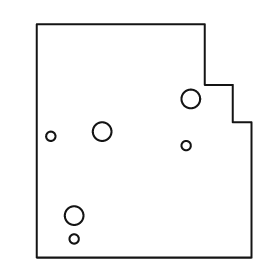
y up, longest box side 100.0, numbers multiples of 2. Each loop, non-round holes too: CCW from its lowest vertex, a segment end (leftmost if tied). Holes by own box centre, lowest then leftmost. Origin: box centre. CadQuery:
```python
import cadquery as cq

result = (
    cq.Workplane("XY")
    .moveTo(-46.0, -50.0)
    .lineTo(46.0, -50.0)
    .lineTo(46.0, 8.0)
    .lineTo(38.0, 8.0)
    .lineTo(38.0, 24.0)
    .lineTo(26.0, 24.0)
    .lineTo(26.0, 50.0)
    .lineTo(-46.0, 50.0)
    .close()
    .moveTo(-30.0, -42.0)
    .circle(2.0)
    .moveTo(-30.0, -32.0)
    .circle(4.0)
    .moveTo(18.0, -2.0)
    .circle(2.0)
    .moveTo(-40.0, 2.0)
    .circle(2.0)
    .moveTo(-18.0, 4.0)
    .circle(4.0)
    .moveTo(20.0, 18.0)
    .circle(4.0)
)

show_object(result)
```